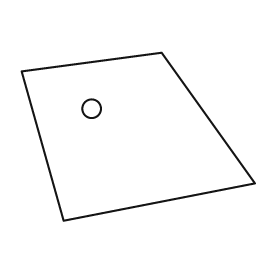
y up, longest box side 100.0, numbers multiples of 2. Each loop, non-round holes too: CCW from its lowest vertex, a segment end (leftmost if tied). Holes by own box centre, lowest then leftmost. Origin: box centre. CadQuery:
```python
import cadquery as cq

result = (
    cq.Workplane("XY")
    .moveTo(-32.0, -36.0)
    .lineTo(50.0, -20.0)
    .lineTo(10.0, 36.0)
    .lineTo(-50.0, 28.0)
    .close()
    .moveTo(-20.0, 12.0)
    .circle(4.0)
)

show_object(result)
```